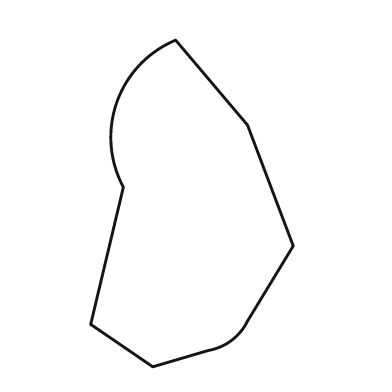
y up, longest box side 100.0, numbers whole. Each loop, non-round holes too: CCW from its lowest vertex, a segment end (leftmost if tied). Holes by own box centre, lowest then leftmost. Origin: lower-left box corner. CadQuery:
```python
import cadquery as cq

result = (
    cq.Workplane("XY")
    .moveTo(19.0, 0.0)
    .lineTo(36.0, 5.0)
    .threePointArc((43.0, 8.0), (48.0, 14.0))
    .lineTo(62.0, 37.0)
    .lineTo(48.0, 74.0)
    .lineTo(26.0, 100.0)
    .threePointArc((8.0, 81.0), (10.0, 55.0))
    .lineTo(0.0, 13.0)
    .close()
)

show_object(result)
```